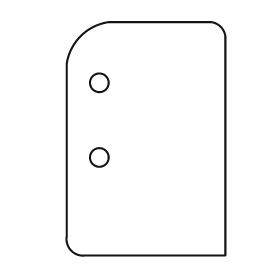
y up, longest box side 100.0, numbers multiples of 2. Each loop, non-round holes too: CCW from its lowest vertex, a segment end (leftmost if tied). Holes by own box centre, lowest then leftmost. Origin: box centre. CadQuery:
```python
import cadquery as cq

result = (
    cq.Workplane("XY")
    .moveTo(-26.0, -50.0)
    .lineTo(34.0, -50.0)
    .lineTo(34.0, 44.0)
    .threePointArc((32.0, 48.0), (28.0, 50.0))
    .lineTo(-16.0, 50.0)
    .threePointArc((-28.0, 44.0), (-34.0, 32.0))
    .lineTo(-34.0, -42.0)
    .threePointArc((-32.0, -48.0), (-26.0, -50.0))
    .close()
    .moveTo(-20.0, -8.0)
    .circle(4.0)
    .moveTo(-20.0, 24.0)
    .circle(4.0)
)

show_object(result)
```